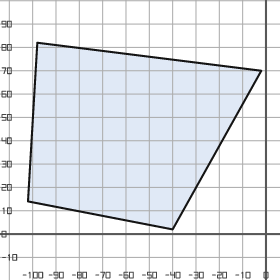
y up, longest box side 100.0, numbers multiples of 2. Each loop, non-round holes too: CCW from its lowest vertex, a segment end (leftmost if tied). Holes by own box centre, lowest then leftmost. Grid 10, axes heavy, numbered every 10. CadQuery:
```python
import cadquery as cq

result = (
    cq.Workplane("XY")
    .moveTo(-40.0, 2.0)
    .lineTo(-2.0, 70.0)
    .lineTo(-98.0, 82.0)
    .lineTo(-102.0, 14.0)
    .close()
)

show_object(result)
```